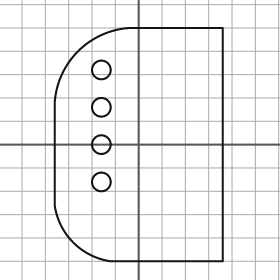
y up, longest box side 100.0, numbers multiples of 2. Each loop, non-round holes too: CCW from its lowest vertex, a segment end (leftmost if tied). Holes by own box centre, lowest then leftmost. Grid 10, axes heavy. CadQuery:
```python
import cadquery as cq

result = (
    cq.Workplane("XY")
    .moveTo(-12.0, -50.0)
    .lineTo(36.0, -50.0)
    .lineTo(36.0, 50.0)
    .lineTo(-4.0, 50.0)
    .threePointArc((-26.0, 40.0), (-36.0, 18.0))
    .lineTo(-36.0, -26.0)
    .threePointArc((-28.0, -42.0), (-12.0, -50.0))
    .close()
    .moveTo(-16.0, -16.0)
    .circle(4.0)
    .moveTo(-16.0, 0.0)
    .circle(4.0)
    .moveTo(-16.0, 16.0)
    .circle(4.0)
    .moveTo(-16.0, 32.0)
    .circle(4.0)
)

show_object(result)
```